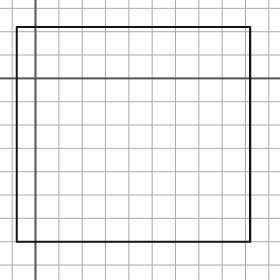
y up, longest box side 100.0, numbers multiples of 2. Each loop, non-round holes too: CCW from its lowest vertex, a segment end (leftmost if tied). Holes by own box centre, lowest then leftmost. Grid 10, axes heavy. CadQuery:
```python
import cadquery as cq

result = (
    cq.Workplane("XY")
    .moveTo(-8.0, -70.0)
    .lineTo(92.0, -70.0)
    .lineTo(92.0, 22.0)
    .lineTo(-8.0, 22.0)
    .close()
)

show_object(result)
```